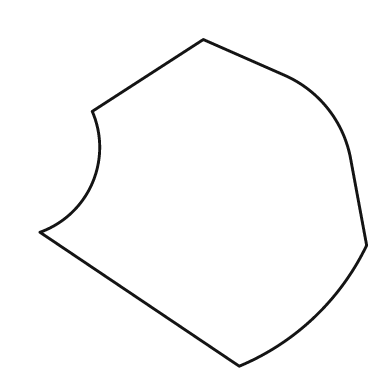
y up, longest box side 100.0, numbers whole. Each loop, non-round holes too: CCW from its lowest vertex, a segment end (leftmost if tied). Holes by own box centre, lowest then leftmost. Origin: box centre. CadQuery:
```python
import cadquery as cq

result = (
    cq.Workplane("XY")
    .moveTo(11.0, -50.0)
    .threePointArc((34.0, -35.0), (50.0, -13.0))
    .lineTo(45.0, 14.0)
    .threePointArc((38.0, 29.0), (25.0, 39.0))
    .lineTo(0.0, 50.0)
    .lineTo(-34.0, 28.0)
    .threePointArc((-34.0, 6.0), (-50.0, -9.0))
    .close()
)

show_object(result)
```